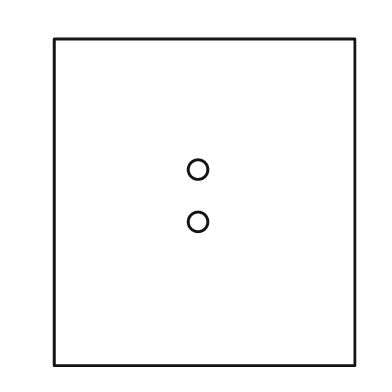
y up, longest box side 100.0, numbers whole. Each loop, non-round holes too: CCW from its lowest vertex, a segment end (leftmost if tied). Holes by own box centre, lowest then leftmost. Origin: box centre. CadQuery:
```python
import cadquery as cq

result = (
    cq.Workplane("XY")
    .moveTo(-46.0, -50.0)
    .lineTo(46.0, -50.0)
    .lineTo(46.0, 50.0)
    .lineTo(-46.0, 50.0)
    .close()
    .moveTo(-2.0, -6.0)
    .circle(3.0)
    .moveTo(-2.0, 10.0)
    .circle(3.0)
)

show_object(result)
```